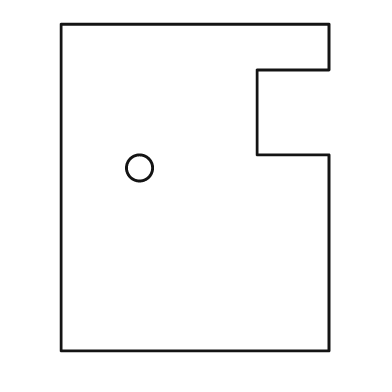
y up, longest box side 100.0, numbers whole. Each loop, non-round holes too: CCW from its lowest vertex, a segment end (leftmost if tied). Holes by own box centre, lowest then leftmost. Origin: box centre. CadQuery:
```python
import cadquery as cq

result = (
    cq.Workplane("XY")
    .moveTo(-41.0, -50.0)
    .lineTo(41.0, -50.0)
    .lineTo(41.0, 10.0)
    .lineTo(19.0, 10.0)
    .lineTo(19.0, 36.0)
    .lineTo(41.0, 36.0)
    .lineTo(41.0, 50.0)
    .lineTo(-41.0, 50.0)
    .close()
    .moveTo(-17.0, 6.0)
    .circle(4.0)
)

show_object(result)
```